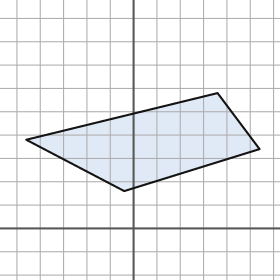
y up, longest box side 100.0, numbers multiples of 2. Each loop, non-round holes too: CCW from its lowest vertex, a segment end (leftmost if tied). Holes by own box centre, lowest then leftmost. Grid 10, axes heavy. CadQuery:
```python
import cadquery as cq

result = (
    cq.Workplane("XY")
    .moveTo(-4.0, 16.0)
    .lineTo(54.0, 34.0)
    .lineTo(36.0, 58.0)
    .lineTo(-46.0, 38.0)
    .close()
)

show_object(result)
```